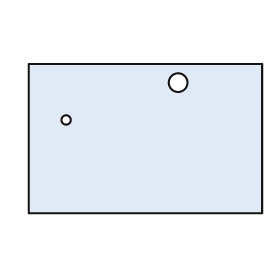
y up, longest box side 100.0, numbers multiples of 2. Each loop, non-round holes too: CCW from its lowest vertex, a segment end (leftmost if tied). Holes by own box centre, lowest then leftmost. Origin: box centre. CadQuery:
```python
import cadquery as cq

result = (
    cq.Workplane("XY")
    .moveTo(-50.0, -32.0)
    .lineTo(50.0, -32.0)
    .lineTo(50.0, 32.0)
    .lineTo(-50.0, 32.0)
    .close()
    .moveTo(-34.0, 8.0)
    .circle(2.0)
    .moveTo(14.0, 24.0)
    .circle(4.0)
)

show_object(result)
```